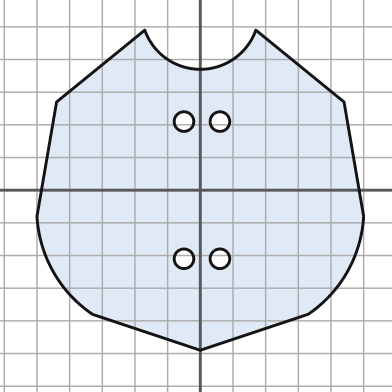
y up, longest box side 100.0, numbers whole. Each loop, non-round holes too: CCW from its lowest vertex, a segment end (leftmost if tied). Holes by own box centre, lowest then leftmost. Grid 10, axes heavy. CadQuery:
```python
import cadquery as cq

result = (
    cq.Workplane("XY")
    .moveTo(0.0, -49.0)
    .lineTo(33.0, -38.0)
    .threePointArc((45.0, -25.0), (50.0, -8.0))
    .lineTo(44.0, 27.0)
    .lineTo(17.0, 49.0)
    .threePointArc((0.0, 37.0), (-17.0, 49.0))
    .lineTo(-44.0, 27.0)
    .lineTo(-50.0, -8.0)
    .threePointArc((-45.0, -25.0), (-33.0, -38.0))
    .close()
    .moveTo(-5.0, -21.0)
    .circle(3.0)
    .moveTo(6.0, -21.0)
    .circle(3.0)
    .moveTo(-5.0, 21.0)
    .circle(3.0)
    .moveTo(6.0, 21.0)
    .circle(3.0)
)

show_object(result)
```